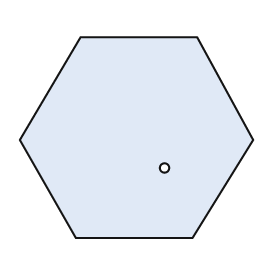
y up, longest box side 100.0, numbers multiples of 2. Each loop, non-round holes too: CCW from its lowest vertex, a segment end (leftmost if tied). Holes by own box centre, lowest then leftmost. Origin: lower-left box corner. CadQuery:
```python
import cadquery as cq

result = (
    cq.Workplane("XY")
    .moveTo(24.0, 0.0)
    .lineTo(74.0, 0.0)
    .lineTo(100.0, 42.0)
    .lineTo(76.0, 86.0)
    .lineTo(26.0, 86.0)
    .lineTo(0.0, 42.0)
    .close()
    .moveTo(62.0, 30.0)
    .circle(2.0)
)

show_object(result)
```